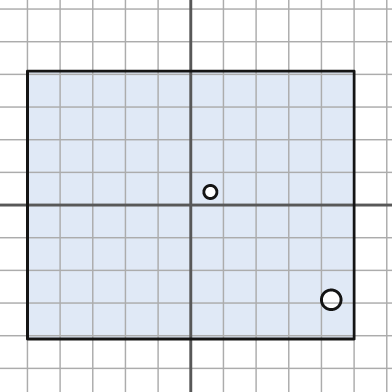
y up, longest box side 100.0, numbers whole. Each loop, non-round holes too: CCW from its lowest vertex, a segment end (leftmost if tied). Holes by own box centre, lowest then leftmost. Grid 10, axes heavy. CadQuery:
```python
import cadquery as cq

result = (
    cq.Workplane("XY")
    .moveTo(-50.0, -41.0)
    .lineTo(50.0, -41.0)
    .lineTo(50.0, 41.0)
    .lineTo(-50.0, 41.0)
    .close()
    .moveTo(43.0, -29.0)
    .circle(3.0)
    .moveTo(6.0, 4.0)
    .circle(2.0)
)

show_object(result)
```